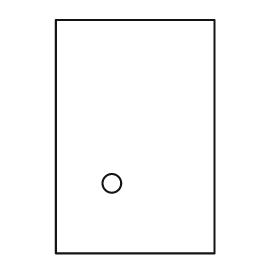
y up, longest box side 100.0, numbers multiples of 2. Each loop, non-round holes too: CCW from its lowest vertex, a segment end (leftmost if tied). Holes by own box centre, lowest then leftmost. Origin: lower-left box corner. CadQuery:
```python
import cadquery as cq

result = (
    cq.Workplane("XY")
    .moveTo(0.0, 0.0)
    .lineTo(68.0, 0.0)
    .lineTo(68.0, 100.0)
    .lineTo(0.0, 100.0)
    .close()
    .moveTo(24.0, 30.0)
    .circle(4.0)
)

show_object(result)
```